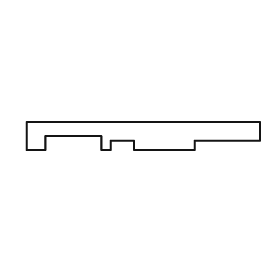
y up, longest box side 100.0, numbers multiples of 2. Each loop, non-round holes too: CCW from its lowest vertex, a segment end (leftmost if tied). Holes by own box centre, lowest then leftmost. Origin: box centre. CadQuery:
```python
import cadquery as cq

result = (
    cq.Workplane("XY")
    .moveTo(-50.0, -6.0)
    .lineTo(-42.0, -6.0)
    .lineTo(-42.0, 0.0)
    .lineTo(-18.0, 0.0)
    .lineTo(-18.0, -6.0)
    .lineTo(-14.0, -6.0)
    .lineTo(-14.0, -2.0)
    .lineTo(-4.0, -2.0)
    .lineTo(-4.0, -6.0)
    .lineTo(22.0, -6.0)
    .lineTo(22.0, -2.0)
    .lineTo(50.0, -2.0)
    .lineTo(50.0, 6.0)
    .lineTo(-50.0, 6.0)
    .close()
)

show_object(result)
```